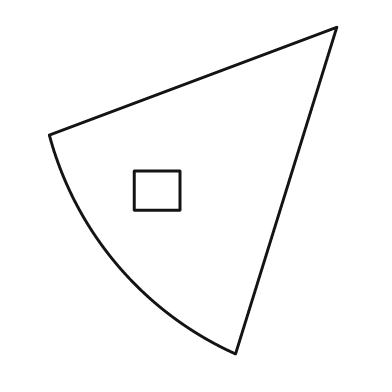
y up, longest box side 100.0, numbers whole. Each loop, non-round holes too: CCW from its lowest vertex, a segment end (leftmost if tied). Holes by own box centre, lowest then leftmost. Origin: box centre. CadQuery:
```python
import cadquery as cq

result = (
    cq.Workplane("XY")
    .moveTo(13.0, -50.0)
    .lineTo(44.0, 50.0)
    .lineTo(-44.0, 17.0)
    .threePointArc((-23.0, -23.0), (13.0, -50.0))
    .close()
    .moveTo(-18.0, -6.0)
    .lineTo(-4.0, -6.0)
    .lineTo(-4.0, 6.0)
    .lineTo(-18.0, 6.0)
    .close()
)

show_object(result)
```